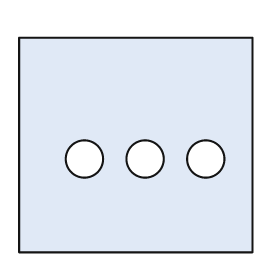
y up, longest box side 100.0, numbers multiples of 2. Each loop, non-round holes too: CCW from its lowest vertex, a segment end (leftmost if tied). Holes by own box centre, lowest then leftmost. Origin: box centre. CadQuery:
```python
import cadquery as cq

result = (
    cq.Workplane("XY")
    .moveTo(-50.0, -46.0)
    .lineTo(50.0, -46.0)
    .lineTo(50.0, 46.0)
    .lineTo(-50.0, 46.0)
    .close()
    .moveTo(-22.0, -6.0)
    .circle(8.0)
    .moveTo(4.0, -6.0)
    .circle(8.0)
    .moveTo(30.0, -6.0)
    .circle(8.0)
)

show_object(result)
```